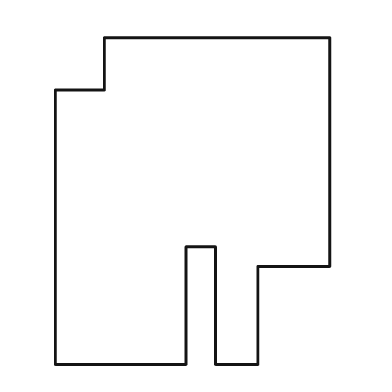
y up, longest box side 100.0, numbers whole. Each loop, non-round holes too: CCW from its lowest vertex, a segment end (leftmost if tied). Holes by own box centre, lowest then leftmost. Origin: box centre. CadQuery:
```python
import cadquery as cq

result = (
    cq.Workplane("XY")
    .moveTo(-42.0, -50.0)
    .lineTo(-2.0, -50.0)
    .lineTo(-2.0, -14.0)
    .lineTo(7.0, -14.0)
    .lineTo(7.0, -50.0)
    .lineTo(20.0, -50.0)
    .lineTo(20.0, -20.0)
    .lineTo(42.0, -20.0)
    .lineTo(42.0, 50.0)
    .lineTo(-27.0, 50.0)
    .lineTo(-27.0, 34.0)
    .lineTo(-42.0, 34.0)
    .close()
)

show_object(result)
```